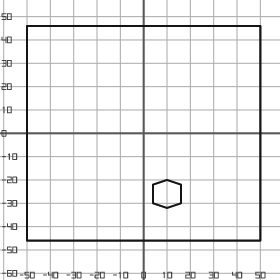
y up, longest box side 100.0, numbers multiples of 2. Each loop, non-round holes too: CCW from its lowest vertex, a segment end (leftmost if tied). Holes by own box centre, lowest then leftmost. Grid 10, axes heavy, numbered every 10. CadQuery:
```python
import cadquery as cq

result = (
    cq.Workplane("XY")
    .moveTo(-50.0, -46.0)
    .lineTo(50.0, -46.0)
    .lineTo(50.0, 46.0)
    .lineTo(-50.0, 46.0)
    .close()
    .moveTo(10.0, -32.0)
    .lineTo(16.0, -30.0)
    .lineTo(16.0, -22.0)
    .lineTo(10.0, -20.0)
    .lineTo(4.0, -22.0)
    .lineTo(4.0, -30.0)
    .close()
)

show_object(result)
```